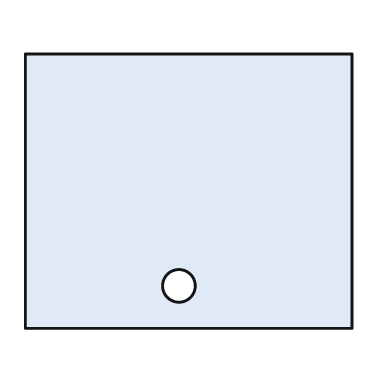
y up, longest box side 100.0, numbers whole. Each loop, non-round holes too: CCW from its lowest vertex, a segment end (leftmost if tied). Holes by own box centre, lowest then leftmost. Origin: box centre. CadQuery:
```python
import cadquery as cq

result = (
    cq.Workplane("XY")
    .moveTo(-50.0, -42.0)
    .lineTo(50.0, -42.0)
    .lineTo(50.0, 42.0)
    .lineTo(-50.0, 42.0)
    .close()
    .moveTo(-3.0, -29.0)
    .circle(5.0)
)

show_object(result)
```